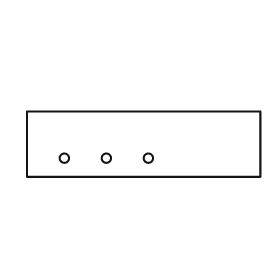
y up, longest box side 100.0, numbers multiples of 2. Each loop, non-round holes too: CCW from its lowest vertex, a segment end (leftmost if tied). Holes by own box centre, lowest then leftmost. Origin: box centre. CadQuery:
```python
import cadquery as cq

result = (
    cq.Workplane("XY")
    .moveTo(-50.0, -14.0)
    .lineTo(50.0, -14.0)
    .lineTo(50.0, 14.0)
    .lineTo(-50.0, 14.0)
    .close()
    .moveTo(-34.0, -6.0)
    .circle(2.0)
    .moveTo(-16.0, -6.0)
    .circle(2.0)
    .moveTo(2.0, -6.0)
    .circle(2.0)
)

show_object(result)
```